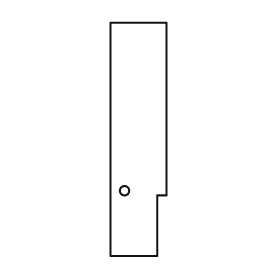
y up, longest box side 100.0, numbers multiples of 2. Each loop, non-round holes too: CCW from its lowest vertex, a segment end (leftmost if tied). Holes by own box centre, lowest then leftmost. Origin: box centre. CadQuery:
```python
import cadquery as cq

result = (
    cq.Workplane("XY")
    .moveTo(-12.0, -50.0)
    .lineTo(8.0, -50.0)
    .lineTo(8.0, -24.0)
    .lineTo(12.0, -24.0)
    .lineTo(12.0, 50.0)
    .lineTo(-12.0, 50.0)
    .close()
    .moveTo(-6.0, -22.0)
    .circle(2.0)
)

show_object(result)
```